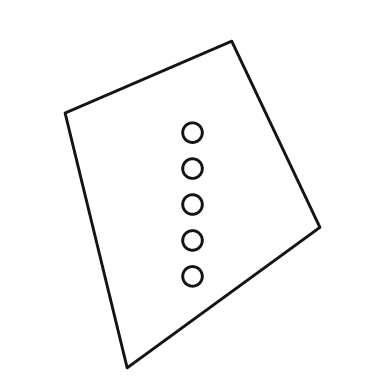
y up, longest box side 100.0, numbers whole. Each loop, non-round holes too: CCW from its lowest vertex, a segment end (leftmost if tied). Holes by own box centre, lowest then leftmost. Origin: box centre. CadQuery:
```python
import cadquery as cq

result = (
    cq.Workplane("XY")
    .moveTo(-20.0, -50.0)
    .lineTo(39.0, -7.0)
    .lineTo(12.0, 50.0)
    .lineTo(-39.0, 28.0)
    .close()
    .moveTo(0.0, -22.0)
    .circle(3.0)
    .moveTo(0.0, -11.0)
    .circle(3.0)
    .moveTo(0.0, 0.0)
    .circle(3.0)
    .moveTo(0.0, 11.0)
    .circle(3.0)
    .moveTo(0.0, 22.0)
    .circle(3.0)
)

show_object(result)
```